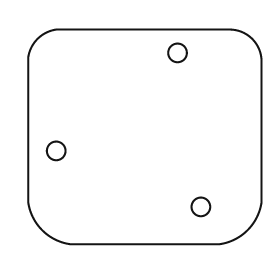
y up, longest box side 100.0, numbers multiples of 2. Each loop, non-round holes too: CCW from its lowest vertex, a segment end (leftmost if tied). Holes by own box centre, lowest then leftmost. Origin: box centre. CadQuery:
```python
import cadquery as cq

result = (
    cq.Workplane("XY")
    .moveTo(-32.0, -46.0)
    .lineTo(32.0, -46.0)
    .threePointArc((44.0, -40.0), (50.0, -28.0))
    .lineTo(50.0, 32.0)
    .threePointArc((46.0, 42.0), (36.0, 46.0))
    .lineTo(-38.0, 46.0)
    .threePointArc((-46.0, 42.0), (-50.0, 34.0))
    .lineTo(-50.0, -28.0)
    .threePointArc((-44.0, -40.0), (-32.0, -46.0))
    .close()
    .moveTo(24.0, -30.0)
    .circle(4.0)
    .moveTo(-38.0, -6.0)
    .circle(4.0)
    .moveTo(14.0, 36.0)
    .circle(4.0)
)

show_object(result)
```